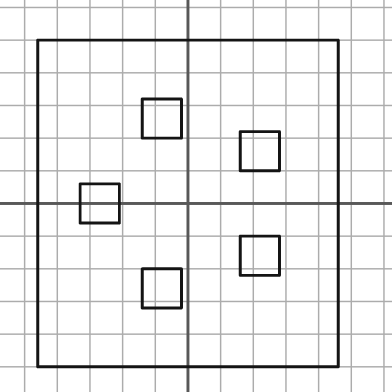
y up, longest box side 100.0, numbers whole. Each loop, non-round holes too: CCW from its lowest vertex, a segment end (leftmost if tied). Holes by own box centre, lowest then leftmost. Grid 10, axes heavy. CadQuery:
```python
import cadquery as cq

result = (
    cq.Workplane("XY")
    .moveTo(-46.0, -50.0)
    .lineTo(46.0, -50.0)
    .lineTo(46.0, 50.0)
    .lineTo(-46.0, 50.0)
    .close()
    .moveTo(-14.0, -32.0)
    .lineTo(-2.0, -32.0)
    .lineTo(-2.0, -20.0)
    .lineTo(-14.0, -20.0)
    .close()
    .moveTo(16.0, -22.0)
    .lineTo(28.0, -22.0)
    .lineTo(28.0, -10.0)
    .lineTo(16.0, -10.0)
    .close()
    .moveTo(-33.0, -6.0)
    .lineTo(-21.0, -6.0)
    .lineTo(-21.0, 6.0)
    .lineTo(-33.0, 6.0)
    .close()
    .moveTo(16.0, 10.0)
    .lineTo(28.0, 10.0)
    .lineTo(28.0, 22.0)
    .lineTo(16.0, 22.0)
    .close()
    .moveTo(-14.0, 20.0)
    .lineTo(-2.0, 20.0)
    .lineTo(-2.0, 32.0)
    .lineTo(-14.0, 32.0)
    .close()
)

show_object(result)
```